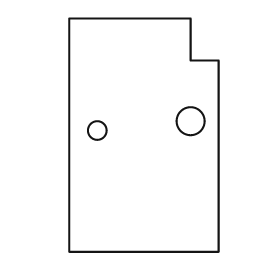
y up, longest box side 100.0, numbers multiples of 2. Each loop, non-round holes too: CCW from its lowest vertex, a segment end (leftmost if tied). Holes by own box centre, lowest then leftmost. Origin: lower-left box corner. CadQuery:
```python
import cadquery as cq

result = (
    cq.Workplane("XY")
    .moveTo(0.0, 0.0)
    .lineTo(64.0, 0.0)
    .lineTo(64.0, 82.0)
    .lineTo(52.0, 82.0)
    .lineTo(52.0, 100.0)
    .lineTo(0.0, 100.0)
    .close()
    .moveTo(12.0, 52.0)
    .circle(4.0)
    .moveTo(52.0, 56.0)
    .circle(6.0)
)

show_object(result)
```